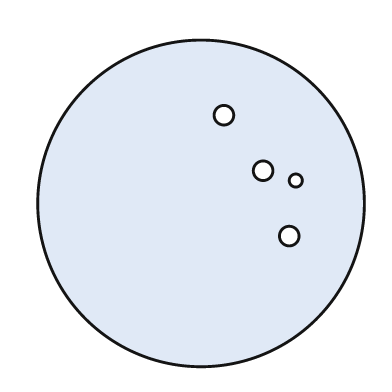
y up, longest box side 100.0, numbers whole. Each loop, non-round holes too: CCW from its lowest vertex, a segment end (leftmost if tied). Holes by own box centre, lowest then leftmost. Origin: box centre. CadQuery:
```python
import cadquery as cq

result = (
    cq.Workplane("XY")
    .moveTo(0.0, 0.0)
    .circle(50.0)
    .moveTo(27.0, -10.0)
    .circle(3.0)
    .moveTo(29.0, 7.0)
    .circle(2.0)
    .moveTo(19.0, 10.0)
    .circle(3.0)
    .moveTo(7.0, 27.0)
    .circle(3.0)
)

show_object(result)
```